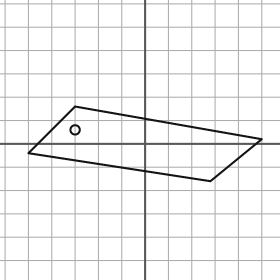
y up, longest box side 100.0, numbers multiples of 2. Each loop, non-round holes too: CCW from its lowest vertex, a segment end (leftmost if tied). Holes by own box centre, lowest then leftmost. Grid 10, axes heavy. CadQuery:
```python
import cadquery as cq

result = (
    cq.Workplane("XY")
    .moveTo(28.0, -16.0)
    .lineTo(50.0, 2.0)
    .lineTo(-30.0, 16.0)
    .lineTo(-50.0, -4.0)
    .close()
    .moveTo(-30.0, 6.0)
    .circle(2.0)
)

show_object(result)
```